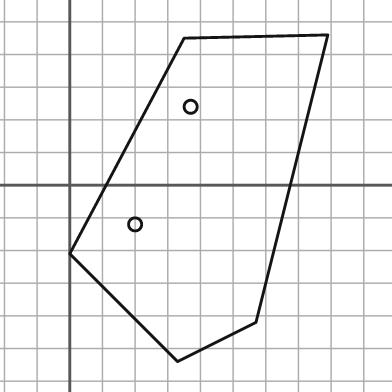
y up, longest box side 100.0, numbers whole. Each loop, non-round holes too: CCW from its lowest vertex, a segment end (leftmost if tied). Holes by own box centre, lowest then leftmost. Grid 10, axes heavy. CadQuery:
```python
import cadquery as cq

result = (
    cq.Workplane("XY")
    .moveTo(33.0, -54.0)
    .lineTo(57.0, -42.0)
    .lineTo(79.0, 46.0)
    .lineTo(35.0, 45.0)
    .lineTo(0.0, -21.0)
    .close()
    .moveTo(20.0, -12.0)
    .circle(2.0)
    .moveTo(37.0, 24.0)
    .circle(2.0)
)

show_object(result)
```